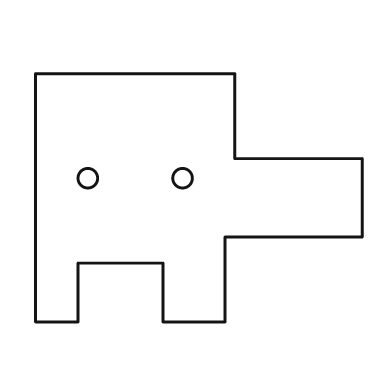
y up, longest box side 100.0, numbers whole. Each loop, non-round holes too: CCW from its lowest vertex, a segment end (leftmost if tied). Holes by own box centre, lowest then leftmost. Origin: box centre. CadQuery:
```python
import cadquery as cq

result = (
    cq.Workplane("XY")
    .moveTo(-50.0, -38.0)
    .lineTo(-37.0, -38.0)
    .lineTo(-37.0, -20.0)
    .lineTo(-11.0, -20.0)
    .lineTo(-11.0, -38.0)
    .lineTo(8.0, -38.0)
    .lineTo(8.0, -12.0)
    .lineTo(50.0, -12.0)
    .lineTo(50.0, 12.0)
    .lineTo(11.0, 12.0)
    .lineTo(11.0, 38.0)
    .lineTo(-50.0, 38.0)
    .close()
    .moveTo(-34.0, 6.0)
    .circle(3.0)
    .moveTo(-5.0, 6.0)
    .circle(3.0)
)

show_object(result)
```